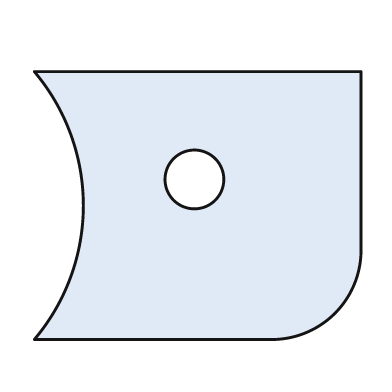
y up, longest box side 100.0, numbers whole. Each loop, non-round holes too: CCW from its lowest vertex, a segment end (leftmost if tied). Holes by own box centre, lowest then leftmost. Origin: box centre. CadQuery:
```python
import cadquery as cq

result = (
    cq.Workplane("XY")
    .moveTo(-50.0, -41.0)
    .lineTo(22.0, -41.0)
    .threePointArc((42.0, -33.0), (50.0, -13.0))
    .lineTo(50.0, 41.0)
    .lineTo(-50.0, 41.0)
    .threePointArc((-35.0, 0.0), (-50.0, -41.0))
    .close()
    .moveTo(-1.0, 8.0)
    .circle(9.0)
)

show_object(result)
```